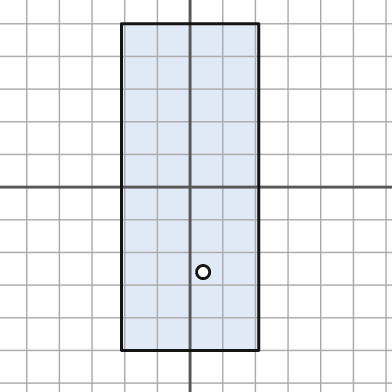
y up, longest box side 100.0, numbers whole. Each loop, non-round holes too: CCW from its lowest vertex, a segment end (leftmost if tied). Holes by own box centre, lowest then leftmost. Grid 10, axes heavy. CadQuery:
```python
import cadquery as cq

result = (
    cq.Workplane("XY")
    .moveTo(-21.0, -50.0)
    .lineTo(21.0, -50.0)
    .lineTo(21.0, 50.0)
    .lineTo(-21.0, 50.0)
    .close()
    .moveTo(4.0, -26.0)
    .circle(2.0)
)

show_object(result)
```